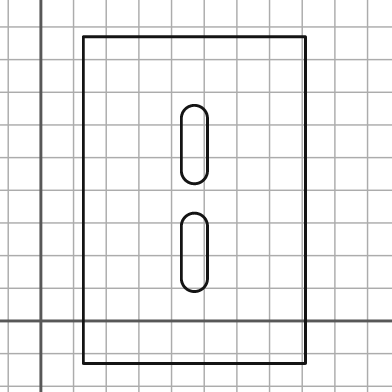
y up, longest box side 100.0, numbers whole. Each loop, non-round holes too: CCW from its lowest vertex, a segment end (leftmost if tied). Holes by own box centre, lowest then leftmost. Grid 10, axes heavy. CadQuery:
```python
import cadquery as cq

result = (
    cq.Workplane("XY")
    .moveTo(13.0, -13.0)
    .lineTo(81.0, -13.0)
    .lineTo(81.0, 87.0)
    .lineTo(13.0, 87.0)
    .close()
    .moveTo(43.0, 13.0)
    .threePointArc((47.0, 9.0), (51.0, 13.0))
    .lineTo(51.0, 29.0)
    .threePointArc((47.0, 33.0), (43.0, 29.0))
    .close()
    .moveTo(43.0, 46.0)
    .threePointArc((47.0, 42.0), (51.0, 46.0))
    .lineTo(51.0, 62.0)
    .threePointArc((47.0, 66.0), (43.0, 62.0))
    .close()
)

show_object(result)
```